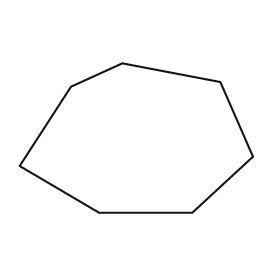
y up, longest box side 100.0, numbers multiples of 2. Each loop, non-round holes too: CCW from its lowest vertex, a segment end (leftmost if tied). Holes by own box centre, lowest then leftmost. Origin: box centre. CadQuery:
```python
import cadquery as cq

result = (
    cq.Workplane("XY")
    .moveTo(-16.0, -32.0)
    .lineTo(24.0, -32.0)
    .lineTo(50.0, -8.0)
    .lineTo(36.0, 24.0)
    .lineTo(-6.0, 32.0)
    .lineTo(-28.0, 22.0)
    .lineTo(-50.0, -12.0)
    .close()
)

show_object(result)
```